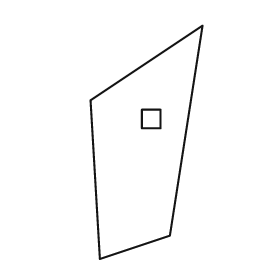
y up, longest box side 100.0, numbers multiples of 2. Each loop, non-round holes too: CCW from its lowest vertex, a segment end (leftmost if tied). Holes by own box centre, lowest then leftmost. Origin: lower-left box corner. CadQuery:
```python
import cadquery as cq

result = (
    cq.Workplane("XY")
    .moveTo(4.0, 0.0)
    .lineTo(34.0, 10.0)
    .lineTo(48.0, 100.0)
    .lineTo(0.0, 68.0)
    .close()
    .moveTo(22.0, 56.0)
    .lineTo(30.0, 56.0)
    .lineTo(30.0, 64.0)
    .lineTo(22.0, 64.0)
    .close()
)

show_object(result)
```